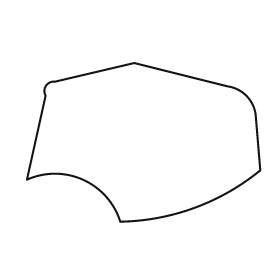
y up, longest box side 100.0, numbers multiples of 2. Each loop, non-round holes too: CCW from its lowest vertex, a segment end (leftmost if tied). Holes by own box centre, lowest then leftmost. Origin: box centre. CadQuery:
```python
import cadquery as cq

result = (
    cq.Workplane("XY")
    .moveTo(-10.0, -34.0)
    .threePointArc((22.0, -28.0), (50.0, -12.0))
    .lineTo(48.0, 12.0)
    .threePointArc((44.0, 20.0), (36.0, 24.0))
    .lineTo(-4.0, 34.0)
    .lineTo(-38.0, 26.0)
    .threePointArc((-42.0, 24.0), (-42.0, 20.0))
    .lineTo(-50.0, -16.0)
    .threePointArc((-26.0, -16.0), (-10.0, -34.0))
    .close()
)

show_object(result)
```